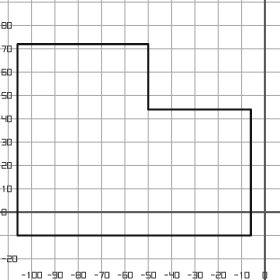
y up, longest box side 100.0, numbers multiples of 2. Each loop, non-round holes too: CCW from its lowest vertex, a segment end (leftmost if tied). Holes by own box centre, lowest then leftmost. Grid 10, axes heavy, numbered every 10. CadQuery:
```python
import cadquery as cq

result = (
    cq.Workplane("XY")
    .moveTo(-106.0, -10.0)
    .lineTo(-6.0, -10.0)
    .lineTo(-6.0, 44.0)
    .lineTo(-50.0, 44.0)
    .lineTo(-50.0, 72.0)
    .lineTo(-106.0, 72.0)
    .close()
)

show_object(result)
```